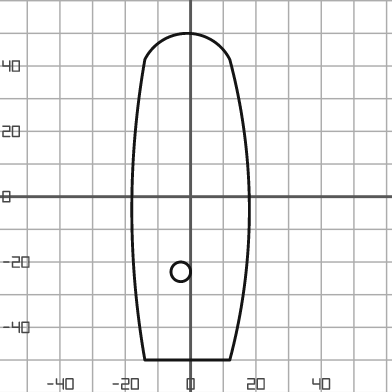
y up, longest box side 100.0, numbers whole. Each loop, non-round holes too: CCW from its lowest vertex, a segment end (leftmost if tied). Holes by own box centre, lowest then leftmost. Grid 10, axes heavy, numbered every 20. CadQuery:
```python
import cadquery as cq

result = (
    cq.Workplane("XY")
    .moveTo(-14.0, -50.0)
    .lineTo(12.0, -50.0)
    .threePointArc((18.0, -4.0), (12.0, 42.0))
    .threePointArc((-1.0, 50.0), (-14.0, 42.0))
    .threePointArc((-18.0, -4.0), (-14.0, -50.0))
    .close()
    .moveTo(-3.0, -23.0)
    .circle(3.0)
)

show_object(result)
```